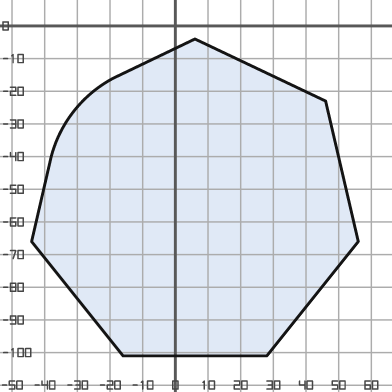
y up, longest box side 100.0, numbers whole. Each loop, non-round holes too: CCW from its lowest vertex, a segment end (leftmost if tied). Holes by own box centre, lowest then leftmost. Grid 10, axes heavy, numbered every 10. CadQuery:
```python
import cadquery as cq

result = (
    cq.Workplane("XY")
    .moveTo(-16.0, -101.0)
    .lineTo(28.0, -101.0)
    .lineTo(56.0, -66.0)
    .lineTo(46.0, -23.0)
    .lineTo(6.0, -4.0)
    .lineTo(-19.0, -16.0)
    .threePointArc((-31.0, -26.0), (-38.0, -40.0))
    .lineTo(-44.0, -66.0)
    .close()
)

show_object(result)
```